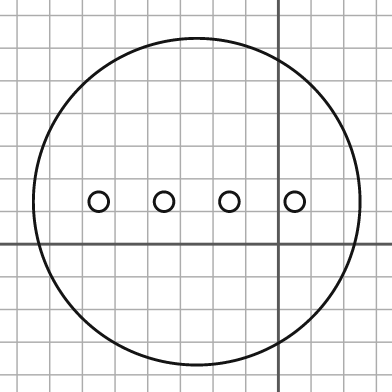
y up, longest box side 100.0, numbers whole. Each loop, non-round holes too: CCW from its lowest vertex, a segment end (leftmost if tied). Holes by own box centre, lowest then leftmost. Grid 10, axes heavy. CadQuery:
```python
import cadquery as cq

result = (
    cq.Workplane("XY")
    .moveTo(-25.0, 13.0)
    .circle(50.0)
    .moveTo(-55.0, 13.0)
    .circle(3.0)
    .moveTo(-35.0, 13.0)
    .circle(3.0)
    .moveTo(-15.0, 13.0)
    .circle(3.0)
    .moveTo(5.0, 13.0)
    .circle(3.0)
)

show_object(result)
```